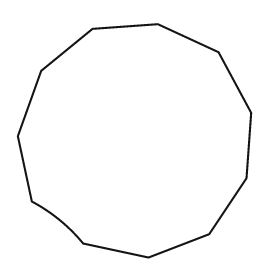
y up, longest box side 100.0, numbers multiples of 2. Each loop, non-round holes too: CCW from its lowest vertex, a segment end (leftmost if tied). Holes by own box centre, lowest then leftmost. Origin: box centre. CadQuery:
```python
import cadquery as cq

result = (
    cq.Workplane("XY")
    .moveTo(6.0, -50.0)
    .lineTo(32.0, -40.0)
    .lineTo(48.0, -16.0)
    .lineTo(50.0, 12.0)
    .lineTo(36.0, 38.0)
    .lineTo(10.0, 50.0)
    .lineTo(-18.0, 48.0)
    .lineTo(-40.0, 30.0)
    .lineTo(-50.0, 2.0)
    .lineTo(-44.0, -26.0)
    .threePointArc((-32.0, -34.0), (-22.0, -44.0))
    .close()
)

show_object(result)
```